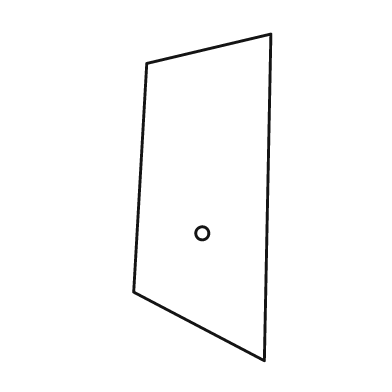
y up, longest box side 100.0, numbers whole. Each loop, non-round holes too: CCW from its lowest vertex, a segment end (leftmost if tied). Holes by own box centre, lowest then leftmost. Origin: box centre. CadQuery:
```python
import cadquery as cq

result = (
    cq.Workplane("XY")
    .moveTo(19.0, -50.0)
    .lineTo(21.0, 50.0)
    .lineTo(-17.0, 41.0)
    .lineTo(-21.0, -29.0)
    .close()
    .moveTo(0.0, -11.0)
    .circle(2.0)
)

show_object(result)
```